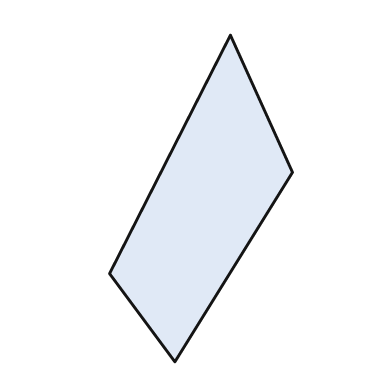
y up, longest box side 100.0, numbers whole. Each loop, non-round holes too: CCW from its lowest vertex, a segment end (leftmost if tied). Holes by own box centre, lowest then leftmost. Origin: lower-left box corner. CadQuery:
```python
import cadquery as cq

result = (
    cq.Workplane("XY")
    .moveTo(20.0, 0.0)
    .lineTo(56.0, 58.0)
    .lineTo(37.0, 100.0)
    .lineTo(0.0, 27.0)
    .close()
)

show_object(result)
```